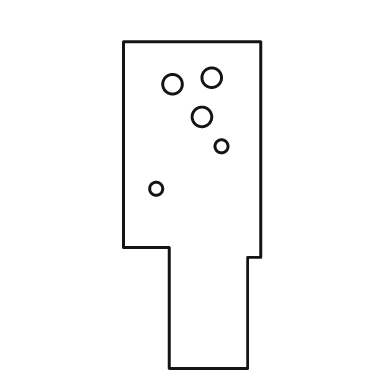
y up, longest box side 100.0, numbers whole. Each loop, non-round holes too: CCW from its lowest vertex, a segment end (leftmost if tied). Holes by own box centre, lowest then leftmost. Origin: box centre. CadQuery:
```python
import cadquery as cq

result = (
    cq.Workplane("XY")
    .moveTo(-7.0, -50.0)
    .lineTo(17.0, -50.0)
    .lineTo(17.0, -16.0)
    .lineTo(21.0, -16.0)
    .lineTo(21.0, 50.0)
    .lineTo(-21.0, 50.0)
    .lineTo(-21.0, -13.0)
    .lineTo(-7.0, -13.0)
    .close()
    .moveTo(-11.0, 5.0)
    .circle(2.0)
    .moveTo(9.0, 18.0)
    .circle(2.0)
    .moveTo(3.0, 27.0)
    .circle(3.0)
    .moveTo(-6.0, 37.0)
    .circle(3.0)
    .moveTo(6.0, 39.0)
    .circle(3.0)
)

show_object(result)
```